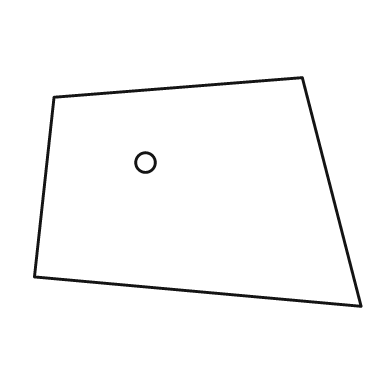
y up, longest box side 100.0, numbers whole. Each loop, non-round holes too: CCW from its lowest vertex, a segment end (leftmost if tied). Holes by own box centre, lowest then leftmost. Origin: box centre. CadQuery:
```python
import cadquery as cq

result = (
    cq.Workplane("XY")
    .moveTo(50.0, -35.0)
    .lineTo(32.0, 35.0)
    .lineTo(-44.0, 29.0)
    .lineTo(-50.0, -26.0)
    .close()
    .moveTo(-16.0, 9.0)
    .circle(3.0)
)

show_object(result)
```